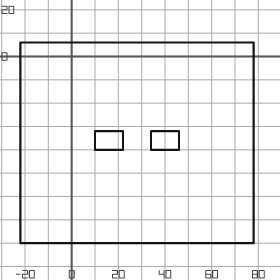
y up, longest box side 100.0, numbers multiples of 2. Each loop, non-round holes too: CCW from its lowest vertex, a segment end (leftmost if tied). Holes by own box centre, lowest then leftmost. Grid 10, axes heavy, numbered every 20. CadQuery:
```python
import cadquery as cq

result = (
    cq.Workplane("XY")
    .moveTo(-22.0, -80.0)
    .lineTo(78.0, -80.0)
    .lineTo(78.0, 6.0)
    .lineTo(-22.0, 6.0)
    .close()
    .moveTo(10.0, -40.0)
    .lineTo(22.0, -40.0)
    .lineTo(22.0, -32.0)
    .lineTo(10.0, -32.0)
    .close()
    .moveTo(34.0, -40.0)
    .lineTo(46.0, -40.0)
    .lineTo(46.0, -32.0)
    .lineTo(34.0, -32.0)
    .close()
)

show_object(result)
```